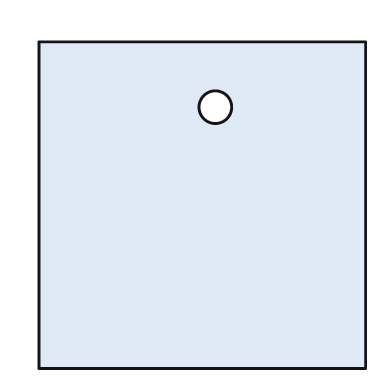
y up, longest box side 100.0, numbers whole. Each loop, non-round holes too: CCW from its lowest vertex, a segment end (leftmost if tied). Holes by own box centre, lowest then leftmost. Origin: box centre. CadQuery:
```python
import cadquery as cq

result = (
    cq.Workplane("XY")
    .moveTo(-50.0, -50.0)
    .lineTo(50.0, -50.0)
    .lineTo(50.0, 50.0)
    .lineTo(-50.0, 50.0)
    .close()
    .moveTo(4.0, 30.0)
    .circle(5.0)
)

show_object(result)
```